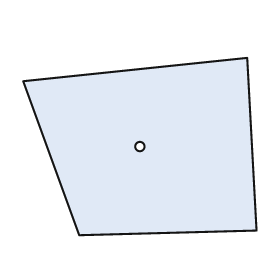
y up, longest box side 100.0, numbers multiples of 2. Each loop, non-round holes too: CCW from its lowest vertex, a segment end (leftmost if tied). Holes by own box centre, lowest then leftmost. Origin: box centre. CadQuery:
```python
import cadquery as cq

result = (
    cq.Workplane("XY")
    .moveTo(-26.0, -38.0)
    .lineTo(50.0, -36.0)
    .lineTo(46.0, 38.0)
    .lineTo(-50.0, 28.0)
    .close()
    .moveTo(0.0, 0.0)
    .circle(2.0)
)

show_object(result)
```